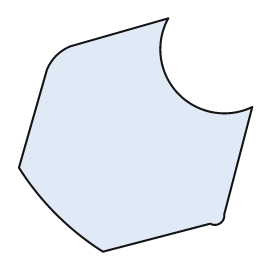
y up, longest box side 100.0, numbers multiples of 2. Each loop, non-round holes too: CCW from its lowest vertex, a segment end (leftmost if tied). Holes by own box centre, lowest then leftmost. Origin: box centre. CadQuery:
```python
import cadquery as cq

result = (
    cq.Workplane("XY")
    .moveTo(-14.0, -50.0)
    .lineTo(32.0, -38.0)
    .threePointArc((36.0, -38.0), (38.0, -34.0))
    .lineTo(50.0, 12.0)
    .threePointArc((18.0, 18.0), (14.0, 50.0))
    .lineTo(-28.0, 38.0)
    .threePointArc((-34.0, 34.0), (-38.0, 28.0))
    .lineTo(-50.0, -14.0)
    .threePointArc((-34.0, -34.0), (-14.0, -50.0))
    .close()
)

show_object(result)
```